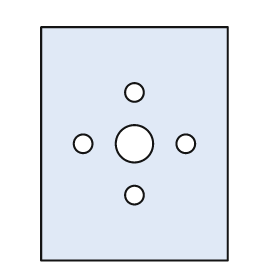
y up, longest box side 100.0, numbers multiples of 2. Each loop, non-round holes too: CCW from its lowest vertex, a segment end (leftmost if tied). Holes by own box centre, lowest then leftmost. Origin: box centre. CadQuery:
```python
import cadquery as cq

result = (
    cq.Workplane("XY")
    .moveTo(-40.0, -50.0)
    .lineTo(40.0, -50.0)
    .lineTo(40.0, 50.0)
    .lineTo(-40.0, 50.0)
    .close()
    .moveTo(0.0, -22.0)
    .circle(4.0)
    .moveTo(-22.0, 0.0)
    .circle(4.0)
    .moveTo(0.0, 0.0)
    .circle(8.0)
    .moveTo(22.0, 0.0)
    .circle(4.0)
    .moveTo(0.0, 22.0)
    .circle(4.0)
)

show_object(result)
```